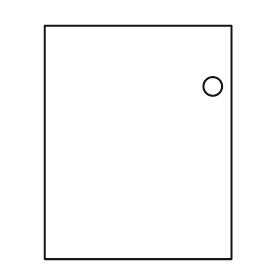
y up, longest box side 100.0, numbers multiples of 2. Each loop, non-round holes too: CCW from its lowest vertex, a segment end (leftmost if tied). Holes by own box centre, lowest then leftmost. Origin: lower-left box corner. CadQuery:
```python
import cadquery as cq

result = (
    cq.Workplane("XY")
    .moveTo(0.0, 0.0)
    .lineTo(80.0, 0.0)
    .lineTo(80.0, 100.0)
    .lineTo(0.0, 100.0)
    .close()
    .moveTo(72.0, 74.0)
    .circle(4.0)
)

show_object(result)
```